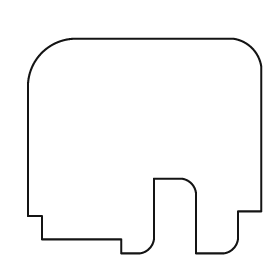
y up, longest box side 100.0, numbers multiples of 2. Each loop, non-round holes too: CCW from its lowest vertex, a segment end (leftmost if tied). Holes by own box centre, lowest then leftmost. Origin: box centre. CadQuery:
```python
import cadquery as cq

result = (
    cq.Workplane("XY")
    .moveTo(-10.0, -46.0)
    .lineTo(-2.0, -46.0)
    .threePointArc((2.0, -44.0), (4.0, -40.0))
    .lineTo(4.0, -14.0)
    .lineTo(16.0, -14.0)
    .threePointArc((20.0, -16.0), (22.0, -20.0))
    .lineTo(22.0, -46.0)
    .lineTo(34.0, -46.0)
    .threePointArc((38.0, -44.0), (40.0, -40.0))
    .lineTo(40.0, -28.0)
    .lineTo(50.0, -28.0)
    .lineTo(50.0, 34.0)
    .threePointArc((46.0, 42.0), (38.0, 46.0))
    .lineTo(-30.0, 46.0)
    .threePointArc((-44.0, 40.0), (-50.0, 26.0))
    .lineTo(-50.0, -30.0)
    .lineTo(-44.0, -30.0)
    .lineTo(-44.0, -40.0)
    .lineTo(-10.0, -40.0)
    .close()
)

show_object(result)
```